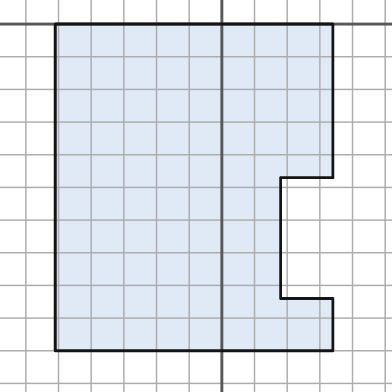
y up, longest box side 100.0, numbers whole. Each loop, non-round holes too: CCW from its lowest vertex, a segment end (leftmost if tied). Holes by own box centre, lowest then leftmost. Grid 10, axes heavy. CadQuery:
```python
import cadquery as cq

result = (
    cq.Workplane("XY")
    .moveTo(-51.0, -100.0)
    .lineTo(34.0, -100.0)
    .lineTo(34.0, -84.0)
    .lineTo(18.0, -84.0)
    .lineTo(18.0, -47.0)
    .lineTo(34.0, -47.0)
    .lineTo(34.0, 0.0)
    .lineTo(-51.0, 0.0)
    .close()
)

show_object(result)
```